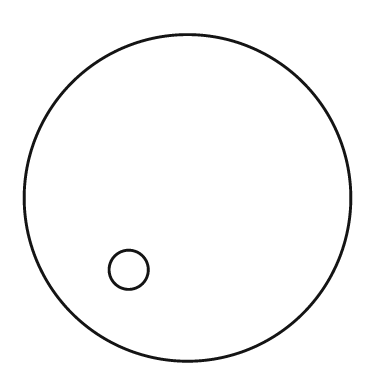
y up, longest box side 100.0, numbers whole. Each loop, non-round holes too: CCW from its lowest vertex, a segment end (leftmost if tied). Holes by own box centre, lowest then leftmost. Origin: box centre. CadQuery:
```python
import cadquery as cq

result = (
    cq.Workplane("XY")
    .moveTo(0.0, 0.0)
    .circle(50.0)
    .moveTo(-18.0, -22.0)
    .circle(6.0)
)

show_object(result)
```